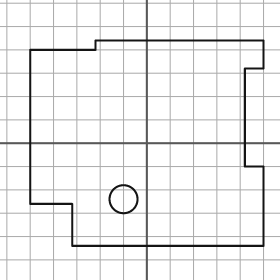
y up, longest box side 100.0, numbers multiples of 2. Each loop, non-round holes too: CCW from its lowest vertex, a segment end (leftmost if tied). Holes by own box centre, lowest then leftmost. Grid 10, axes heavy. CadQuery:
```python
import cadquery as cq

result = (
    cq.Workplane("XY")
    .moveTo(-32.0, -44.0)
    .lineTo(50.0, -44.0)
    .lineTo(50.0, -10.0)
    .lineTo(42.0, -10.0)
    .lineTo(42.0, 32.0)
    .lineTo(50.0, 32.0)
    .lineTo(50.0, 44.0)
    .lineTo(-22.0, 44.0)
    .lineTo(-22.0, 40.0)
    .lineTo(-50.0, 40.0)
    .lineTo(-50.0, -26.0)
    .lineTo(-32.0, -26.0)
    .close()
    .moveTo(-10.0, -24.0)
    .circle(6.0)
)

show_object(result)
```